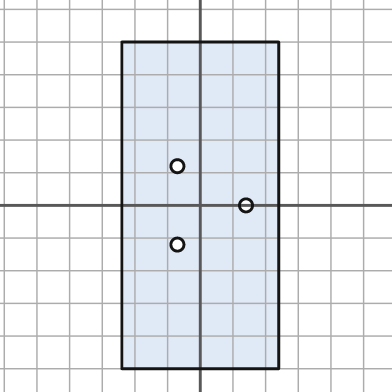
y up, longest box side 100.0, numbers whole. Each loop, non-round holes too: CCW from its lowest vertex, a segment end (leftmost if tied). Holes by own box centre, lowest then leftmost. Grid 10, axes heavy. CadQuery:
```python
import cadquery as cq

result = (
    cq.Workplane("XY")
    .moveTo(-24.0, -50.0)
    .lineTo(24.0, -50.0)
    .lineTo(24.0, 50.0)
    .lineTo(-24.0, 50.0)
    .close()
    .moveTo(-7.0, -12.0)
    .circle(2.0)
    .moveTo(14.0, 0.0)
    .circle(2.0)
    .moveTo(-7.0, 12.0)
    .circle(2.0)
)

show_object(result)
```